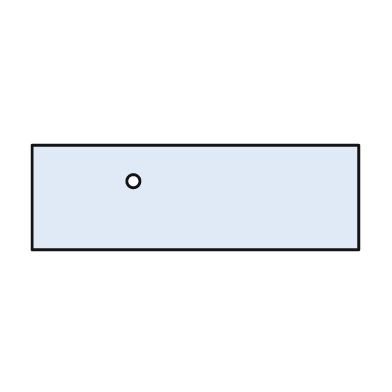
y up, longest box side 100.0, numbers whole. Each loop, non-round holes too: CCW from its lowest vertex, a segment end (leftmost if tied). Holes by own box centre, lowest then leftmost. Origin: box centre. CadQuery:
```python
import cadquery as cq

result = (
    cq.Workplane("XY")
    .moveTo(-50.0, -16.0)
    .lineTo(50.0, -16.0)
    .lineTo(50.0, 16.0)
    .lineTo(-50.0, 16.0)
    .close()
    .moveTo(-19.0, 5.0)
    .circle(2.0)
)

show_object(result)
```